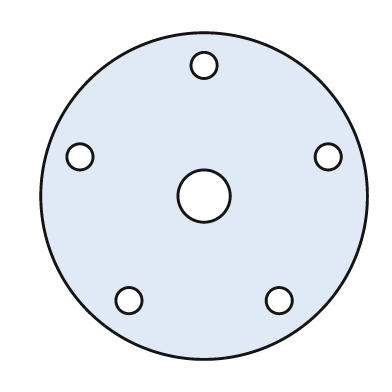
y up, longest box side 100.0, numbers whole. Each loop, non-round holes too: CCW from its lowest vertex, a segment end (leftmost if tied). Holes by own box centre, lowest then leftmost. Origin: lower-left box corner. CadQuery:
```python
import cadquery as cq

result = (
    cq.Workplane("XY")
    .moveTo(50.0, 50.0)
    .circle(50.0)
    .moveTo(27.0, 18.0)
    .circle(4.0)
    .moveTo(73.0, 18.0)
    .circle(4.0)
    .moveTo(50.0, 50.0)
    .circle(8.0)
    .moveTo(12.0, 62.0)
    .circle(4.0)
    .moveTo(88.0, 62.0)
    .circle(4.0)
    .moveTo(50.0, 90.0)
    .circle(4.0)
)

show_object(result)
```